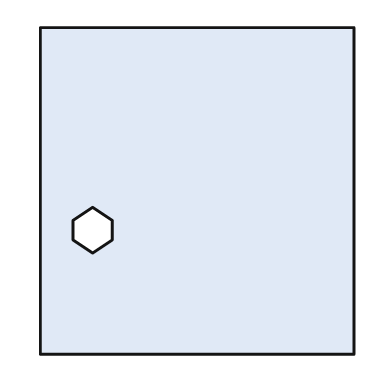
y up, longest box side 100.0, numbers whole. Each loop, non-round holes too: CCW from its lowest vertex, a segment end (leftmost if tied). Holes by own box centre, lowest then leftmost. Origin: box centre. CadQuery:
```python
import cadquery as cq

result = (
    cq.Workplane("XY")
    .moveTo(-48.0, -50.0)
    .lineTo(48.0, -50.0)
    .lineTo(48.0, 50.0)
    .lineTo(-48.0, 50.0)
    .close()
    .moveTo(-32.0, -19.0)
    .lineTo(-26.0, -15.0)
    .lineTo(-26.0, -9.0)
    .lineTo(-32.0, -5.0)
    .lineTo(-38.0, -9.0)
    .lineTo(-38.0, -15.0)
    .close()
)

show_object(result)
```